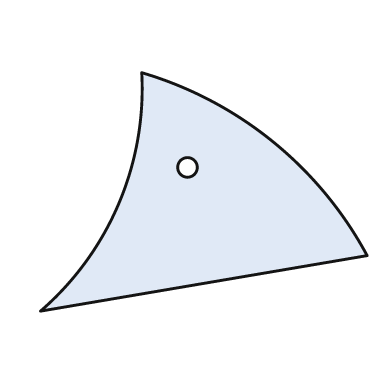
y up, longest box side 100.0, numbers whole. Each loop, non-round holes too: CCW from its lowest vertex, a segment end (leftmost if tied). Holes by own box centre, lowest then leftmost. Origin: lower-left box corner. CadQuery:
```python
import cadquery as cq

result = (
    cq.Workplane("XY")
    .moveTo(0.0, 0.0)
    .lineTo(100.0, 17.0)
    .threePointArc((71.0, 52.0), (31.0, 73.0))
    .threePointArc((24.0, 33.0), (0.0, 0.0))
    .close()
    .moveTo(45.0, 44.0)
    .circle(3.0)
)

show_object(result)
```